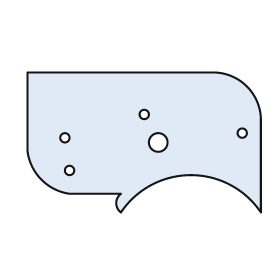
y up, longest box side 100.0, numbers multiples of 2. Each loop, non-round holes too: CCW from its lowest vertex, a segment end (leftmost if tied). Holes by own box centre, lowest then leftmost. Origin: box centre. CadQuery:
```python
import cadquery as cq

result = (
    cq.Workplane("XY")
    .moveTo(-10.0, -30.0)
    .threePointArc((20.0, -14.0), (50.0, -30.0))
    .lineTo(50.0, 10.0)
    .threePointArc((44.0, 24.0), (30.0, 30.0))
    .lineTo(-50.0, 30.0)
    .lineTo(-50.0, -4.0)
    .threePointArc((-44.0, -16.0), (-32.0, -22.0))
    .lineTo(-10.0, -22.0)
    .threePointArc((-12.0, -26.0), (-10.0, -30.0))
    .close()
    .moveTo(-32.0, -12.0)
    .circle(2.0)
    .moveTo(6.0, 0.0)
    .circle(4.0)
    .moveTo(-34.0, 2.0)
    .circle(2.0)
    .moveTo(42.0, 4.0)
    .circle(2.0)
    .moveTo(0.0, 12.0)
    .circle(2.0)
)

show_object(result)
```